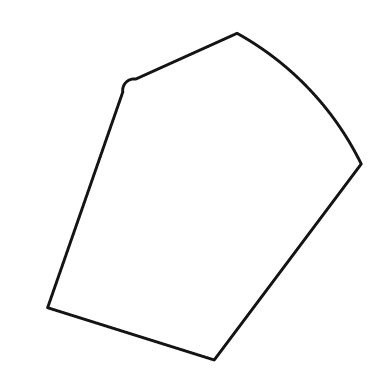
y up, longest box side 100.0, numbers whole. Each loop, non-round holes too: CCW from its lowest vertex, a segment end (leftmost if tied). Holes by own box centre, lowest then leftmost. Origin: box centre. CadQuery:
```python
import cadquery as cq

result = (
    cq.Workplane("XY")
    .moveTo(3.0, -50.0)
    .lineTo(48.0, 10.0)
    .threePointArc((32.0, 33.0), (10.0, 50.0))
    .lineTo(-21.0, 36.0)
    .threePointArc((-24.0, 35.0), (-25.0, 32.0))
    .lineTo(-48.0, -34.0)
    .close()
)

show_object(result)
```